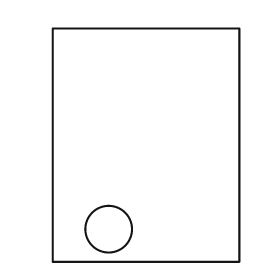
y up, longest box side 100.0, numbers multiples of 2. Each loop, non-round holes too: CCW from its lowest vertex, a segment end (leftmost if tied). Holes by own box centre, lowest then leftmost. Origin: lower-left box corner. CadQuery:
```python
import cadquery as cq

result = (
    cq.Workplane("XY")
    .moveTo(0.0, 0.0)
    .lineTo(80.0, 0.0)
    .lineTo(80.0, 100.0)
    .lineTo(0.0, 100.0)
    .close()
    .moveTo(24.0, 14.0)
    .circle(10.0)
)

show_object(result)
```